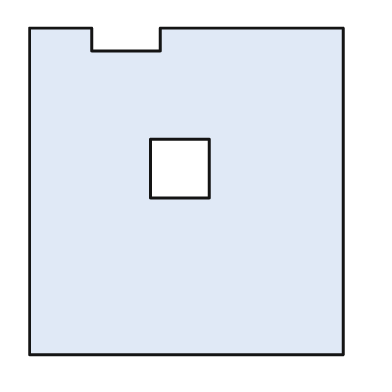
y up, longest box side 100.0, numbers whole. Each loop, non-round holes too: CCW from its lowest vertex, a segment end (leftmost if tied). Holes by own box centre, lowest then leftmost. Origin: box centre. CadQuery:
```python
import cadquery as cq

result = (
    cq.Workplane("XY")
    .moveTo(-48.0, -50.0)
    .lineTo(48.0, -50.0)
    .lineTo(48.0, 50.0)
    .lineTo(-8.0, 50.0)
    .lineTo(-8.0, 43.0)
    .lineTo(-29.0, 43.0)
    .lineTo(-29.0, 50.0)
    .lineTo(-48.0, 50.0)
    .close()
    .moveTo(-11.0, -2.0)
    .lineTo(7.0, -2.0)
    .lineTo(7.0, 16.0)
    .lineTo(-11.0, 16.0)
    .close()
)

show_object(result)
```